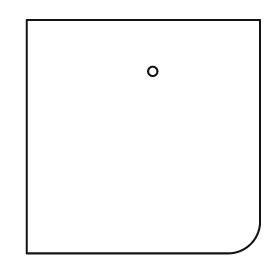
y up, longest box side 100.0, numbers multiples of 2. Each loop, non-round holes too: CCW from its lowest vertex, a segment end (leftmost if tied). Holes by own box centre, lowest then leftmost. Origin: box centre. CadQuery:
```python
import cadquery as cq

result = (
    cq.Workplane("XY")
    .moveTo(-50.0, -50.0)
    .lineTo(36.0, -50.0)
    .threePointArc((46.0, -46.0), (50.0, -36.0))
    .lineTo(50.0, 50.0)
    .lineTo(-50.0, 50.0)
    .close()
    .moveTo(4.0, 28.0)
    .circle(2.0)
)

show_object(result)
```